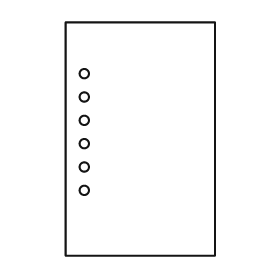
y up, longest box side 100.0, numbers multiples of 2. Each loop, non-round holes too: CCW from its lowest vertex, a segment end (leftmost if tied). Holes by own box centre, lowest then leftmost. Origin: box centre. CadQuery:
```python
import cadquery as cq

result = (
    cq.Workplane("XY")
    .moveTo(-32.0, -50.0)
    .lineTo(32.0, -50.0)
    .lineTo(32.0, 50.0)
    .lineTo(-32.0, 50.0)
    .close()
    .moveTo(-24.0, -22.0)
    .circle(2.0)
    .moveTo(-24.0, -12.0)
    .circle(2.0)
    .moveTo(-24.0, -2.0)
    .circle(2.0)
    .moveTo(-24.0, 8.0)
    .circle(2.0)
    .moveTo(-24.0, 18.0)
    .circle(2.0)
    .moveTo(-24.0, 28.0)
    .circle(2.0)
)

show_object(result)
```